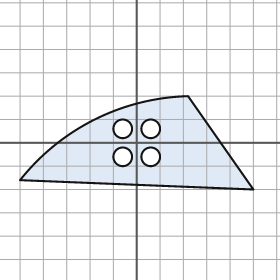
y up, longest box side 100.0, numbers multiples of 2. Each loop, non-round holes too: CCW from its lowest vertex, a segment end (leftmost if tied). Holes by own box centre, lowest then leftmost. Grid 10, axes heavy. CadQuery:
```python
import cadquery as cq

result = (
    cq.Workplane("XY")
    .moveTo(50.0, -20.0)
    .lineTo(22.0, 20.0)
    .threePointArc((-18.0, 10.0), (-50.0, -16.0))
    .close()
    .moveTo(-6.0, -6.0)
    .circle(4.0)
    .moveTo(6.0, -6.0)
    .circle(4.0)
    .moveTo(-6.0, 6.0)
    .circle(4.0)
    .moveTo(6.0, 6.0)
    .circle(4.0)
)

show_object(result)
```